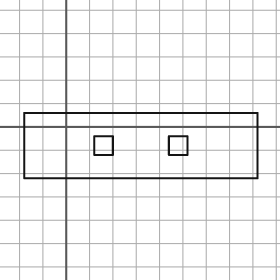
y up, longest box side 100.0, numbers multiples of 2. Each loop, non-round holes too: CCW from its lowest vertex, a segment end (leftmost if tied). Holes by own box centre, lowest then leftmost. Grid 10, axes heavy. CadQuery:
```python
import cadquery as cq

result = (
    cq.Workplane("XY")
    .moveTo(-18.0, -22.0)
    .lineTo(82.0, -22.0)
    .lineTo(82.0, 6.0)
    .lineTo(-18.0, 6.0)
    .close()
    .moveTo(12.0, -12.0)
    .lineTo(20.0, -12.0)
    .lineTo(20.0, -4.0)
    .lineTo(12.0, -4.0)
    .close()
    .moveTo(44.0, -12.0)
    .lineTo(52.0, -12.0)
    .lineTo(52.0, -4.0)
    .lineTo(44.0, -4.0)
    .close()
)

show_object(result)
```